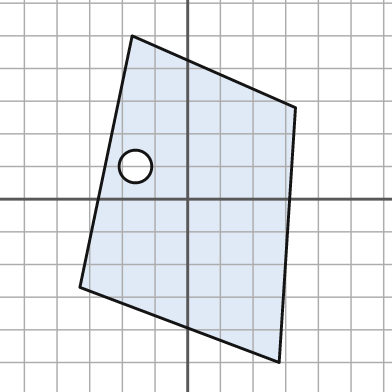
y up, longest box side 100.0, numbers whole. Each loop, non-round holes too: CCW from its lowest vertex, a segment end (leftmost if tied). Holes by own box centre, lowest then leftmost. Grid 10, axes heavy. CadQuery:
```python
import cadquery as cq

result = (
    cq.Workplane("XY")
    .moveTo(28.0, -50.0)
    .lineTo(33.0, 28.0)
    .lineTo(-17.0, 50.0)
    .lineTo(-33.0, -27.0)
    .close()
    .moveTo(-16.0, 10.0)
    .circle(5.0)
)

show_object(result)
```